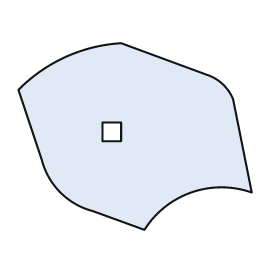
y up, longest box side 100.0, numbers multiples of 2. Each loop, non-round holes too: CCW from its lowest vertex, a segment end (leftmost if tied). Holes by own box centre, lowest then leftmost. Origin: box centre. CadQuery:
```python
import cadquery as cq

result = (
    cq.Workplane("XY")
    .moveTo(4.0, -40.0)
    .threePointArc((24.0, -24.0), (50.0, -24.0))
    .lineTo(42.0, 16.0)
    .threePointArc((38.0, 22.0), (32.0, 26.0))
    .lineTo(-6.0, 40.0)
    .threePointArc((-30.0, 34.0), (-50.0, 20.0))
    .lineTo(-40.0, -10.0)
    .threePointArc((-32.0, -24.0), (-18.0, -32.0))
    .close()
    .moveTo(-14.0, -2.0)
    .lineTo(-6.0, -2.0)
    .lineTo(-6.0, 6.0)
    .lineTo(-14.0, 6.0)
    .close()
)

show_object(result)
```